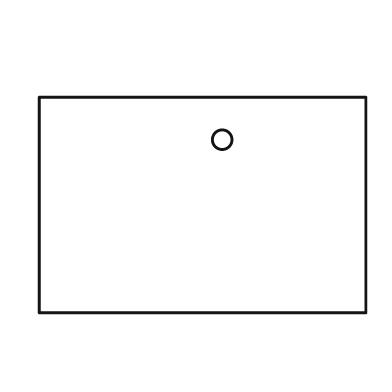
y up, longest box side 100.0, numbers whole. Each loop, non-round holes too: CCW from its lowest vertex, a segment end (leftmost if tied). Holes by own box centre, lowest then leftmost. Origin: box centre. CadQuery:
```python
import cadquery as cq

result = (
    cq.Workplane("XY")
    .moveTo(-50.0, -33.0)
    .lineTo(50.0, -33.0)
    .lineTo(50.0, 33.0)
    .lineTo(-50.0, 33.0)
    .close()
    .moveTo(6.0, 20.0)
    .circle(3.0)
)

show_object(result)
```